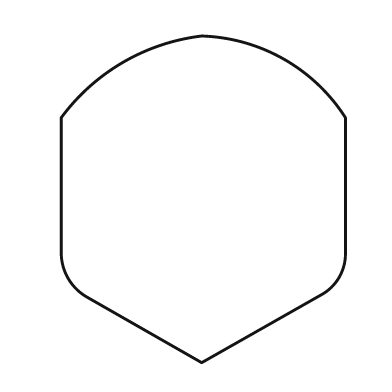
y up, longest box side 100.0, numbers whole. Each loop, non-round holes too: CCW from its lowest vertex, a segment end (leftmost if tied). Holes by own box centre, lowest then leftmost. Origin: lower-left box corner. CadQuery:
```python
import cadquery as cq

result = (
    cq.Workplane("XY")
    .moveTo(43.0, 0.0)
    .lineTo(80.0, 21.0)
    .threePointArc((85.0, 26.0), (87.0, 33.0))
    .lineTo(87.0, 75.0)
    .threePointArc((68.0, 93.0), (43.0, 100.0))
    .threePointArc((19.0, 92.0), (0.0, 75.0))
    .lineTo(0.0, 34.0)
    .threePointArc((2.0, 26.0), (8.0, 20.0))
    .close()
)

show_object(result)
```